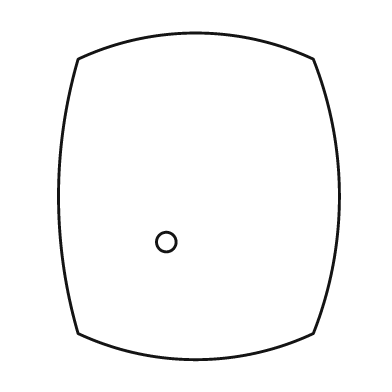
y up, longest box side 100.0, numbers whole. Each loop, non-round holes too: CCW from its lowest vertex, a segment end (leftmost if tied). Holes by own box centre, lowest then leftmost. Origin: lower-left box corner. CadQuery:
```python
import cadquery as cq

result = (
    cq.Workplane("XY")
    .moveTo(6.0, 8.0)
    .threePointArc((42.0, 0.0), (78.0, 8.0))
    .threePointArc((86.0, 50.0), (78.0, 92.0))
    .threePointArc((42.0, 100.0), (6.0, 92.0))
    .threePointArc((0.0, 50.0), (6.0, 8.0))
    .close()
    .moveTo(33.0, 36.0)
    .circle(3.0)
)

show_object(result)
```